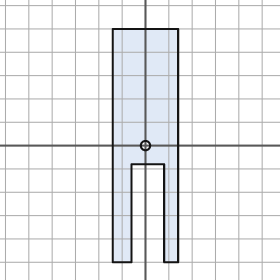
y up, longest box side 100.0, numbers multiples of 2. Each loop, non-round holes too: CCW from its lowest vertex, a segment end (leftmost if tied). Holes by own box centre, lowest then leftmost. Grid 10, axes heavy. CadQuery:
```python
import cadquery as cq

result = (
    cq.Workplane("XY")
    .moveTo(-14.0, -50.0)
    .lineTo(-6.0, -50.0)
    .lineTo(-6.0, -8.0)
    .lineTo(8.0, -8.0)
    .lineTo(8.0, -50.0)
    .lineTo(14.0, -50.0)
    .lineTo(14.0, 50.0)
    .lineTo(-14.0, 50.0)
    .close()
    .moveTo(0.0, 0.0)
    .circle(2.0)
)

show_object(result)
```